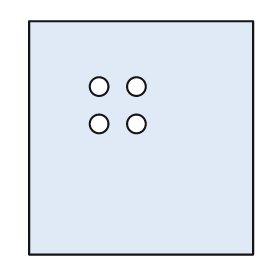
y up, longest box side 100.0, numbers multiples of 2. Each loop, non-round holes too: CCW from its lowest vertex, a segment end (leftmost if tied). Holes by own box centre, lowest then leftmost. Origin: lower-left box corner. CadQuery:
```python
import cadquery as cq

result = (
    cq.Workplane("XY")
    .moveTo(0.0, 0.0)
    .lineTo(96.0, 0.0)
    .lineTo(96.0, 100.0)
    .lineTo(0.0, 100.0)
    .close()
    .moveTo(30.0, 56.0)
    .circle(4.0)
    .moveTo(46.0, 56.0)
    .circle(4.0)
    .moveTo(30.0, 72.0)
    .circle(4.0)
    .moveTo(46.0, 72.0)
    .circle(4.0)
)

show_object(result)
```